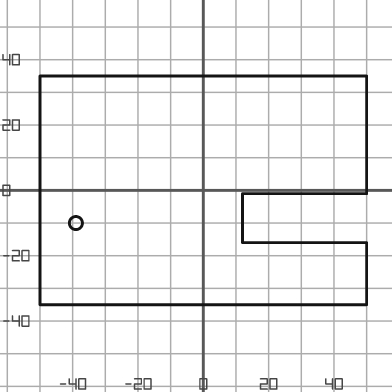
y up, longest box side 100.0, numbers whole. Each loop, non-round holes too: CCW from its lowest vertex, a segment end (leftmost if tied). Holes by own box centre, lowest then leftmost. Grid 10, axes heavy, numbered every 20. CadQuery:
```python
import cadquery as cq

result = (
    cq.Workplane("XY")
    .moveTo(-50.0, -35.0)
    .lineTo(50.0, -35.0)
    .lineTo(50.0, -16.0)
    .lineTo(12.0, -16.0)
    .lineTo(12.0, -1.0)
    .lineTo(50.0, -1.0)
    .lineTo(50.0, 35.0)
    .lineTo(-50.0, 35.0)
    .close()
    .moveTo(-39.0, -10.0)
    .circle(2.0)
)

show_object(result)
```